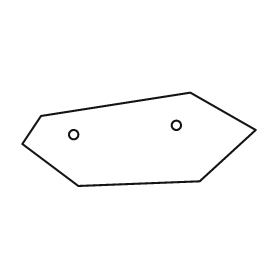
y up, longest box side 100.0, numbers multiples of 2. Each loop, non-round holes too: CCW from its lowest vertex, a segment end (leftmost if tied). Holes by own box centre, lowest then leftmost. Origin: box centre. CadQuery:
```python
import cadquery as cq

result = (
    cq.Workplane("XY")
    .moveTo(-26.0, -20.0)
    .lineTo(26.0, -18.0)
    .lineTo(50.0, 4.0)
    .lineTo(22.0, 20.0)
    .lineTo(-42.0, 10.0)
    .lineTo(-50.0, -2.0)
    .close()
    .moveTo(-28.0, 2.0)
    .circle(2.0)
    .moveTo(16.0, 6.0)
    .circle(2.0)
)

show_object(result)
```